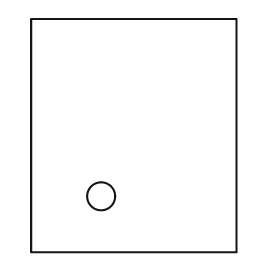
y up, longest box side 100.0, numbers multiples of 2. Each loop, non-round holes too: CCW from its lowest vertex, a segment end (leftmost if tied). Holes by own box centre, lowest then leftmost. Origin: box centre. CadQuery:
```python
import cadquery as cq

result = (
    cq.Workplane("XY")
    .moveTo(-44.0, -50.0)
    .lineTo(44.0, -50.0)
    .lineTo(44.0, 50.0)
    .lineTo(-44.0, 50.0)
    .close()
    .moveTo(-14.0, -26.0)
    .circle(6.0)
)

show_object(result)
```